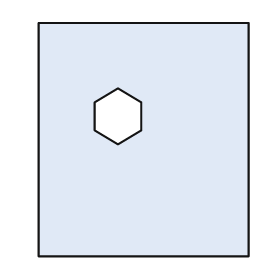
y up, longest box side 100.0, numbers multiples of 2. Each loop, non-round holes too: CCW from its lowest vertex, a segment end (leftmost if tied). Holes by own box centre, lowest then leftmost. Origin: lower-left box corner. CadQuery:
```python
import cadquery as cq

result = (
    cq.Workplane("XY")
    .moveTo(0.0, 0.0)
    .lineTo(90.0, 0.0)
    .lineTo(90.0, 100.0)
    .lineTo(0.0, 100.0)
    .close()
    .moveTo(34.0, 48.0)
    .lineTo(44.0, 54.0)
    .lineTo(44.0, 66.0)
    .lineTo(34.0, 72.0)
    .lineTo(24.0, 66.0)
    .lineTo(24.0, 54.0)
    .close()
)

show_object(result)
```